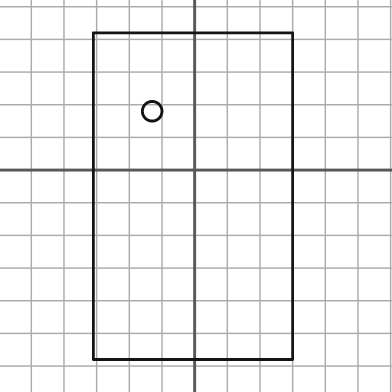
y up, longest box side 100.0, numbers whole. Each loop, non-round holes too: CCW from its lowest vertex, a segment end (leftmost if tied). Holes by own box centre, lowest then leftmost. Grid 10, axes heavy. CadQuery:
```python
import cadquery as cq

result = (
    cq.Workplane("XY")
    .moveTo(-31.0, -58.0)
    .lineTo(30.0, -58.0)
    .lineTo(30.0, 42.0)
    .lineTo(-31.0, 42.0)
    .close()
    .moveTo(-13.0, 18.0)
    .circle(3.0)
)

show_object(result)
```